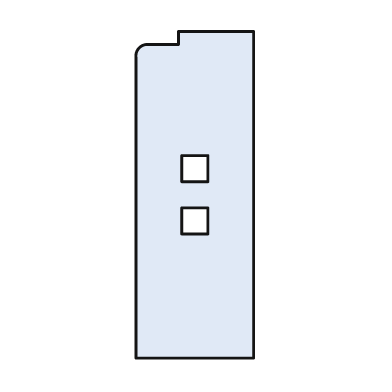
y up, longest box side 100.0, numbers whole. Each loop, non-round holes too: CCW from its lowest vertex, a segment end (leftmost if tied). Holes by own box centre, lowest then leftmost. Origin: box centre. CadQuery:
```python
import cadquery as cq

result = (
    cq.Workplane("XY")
    .moveTo(-18.0, -50.0)
    .lineTo(18.0, -50.0)
    .lineTo(18.0, 50.0)
    .lineTo(-5.0, 50.0)
    .lineTo(-5.0, 46.0)
    .lineTo(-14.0, 46.0)
    .threePointArc((-17.0, 45.0), (-18.0, 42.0))
    .close()
    .moveTo(-4.0, -12.0)
    .lineTo(4.0, -12.0)
    .lineTo(4.0, -4.0)
    .lineTo(-4.0, -4.0)
    .close()
    .moveTo(-4.0, 4.0)
    .lineTo(4.0, 4.0)
    .lineTo(4.0, 12.0)
    .lineTo(-4.0, 12.0)
    .close()
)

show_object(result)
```